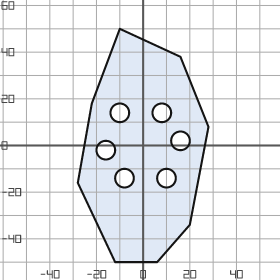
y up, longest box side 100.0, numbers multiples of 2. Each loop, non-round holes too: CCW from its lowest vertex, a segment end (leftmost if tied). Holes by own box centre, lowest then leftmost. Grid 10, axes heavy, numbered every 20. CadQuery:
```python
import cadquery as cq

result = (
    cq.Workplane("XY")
    .moveTo(-12.0, -50.0)
    .lineTo(6.0, -50.0)
    .lineTo(20.0, -34.0)
    .lineTo(28.0, 8.0)
    .lineTo(16.0, 38.0)
    .lineTo(-10.0, 50.0)
    .lineTo(-22.0, 18.0)
    .lineTo(-28.0, -16.0)
    .close()
    .moveTo(-8.0, -14.0)
    .circle(4.0)
    .moveTo(10.0, -14.0)
    .circle(4.0)
    .moveTo(-16.0, -2.0)
    .circle(4.0)
    .moveTo(16.0, 2.0)
    .circle(4.0)
    .moveTo(-10.0, 14.0)
    .circle(4.0)
    .moveTo(8.0, 14.0)
    .circle(4.0)
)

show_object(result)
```